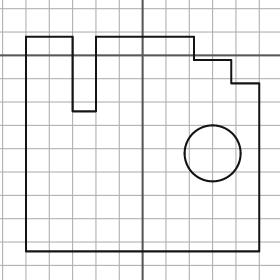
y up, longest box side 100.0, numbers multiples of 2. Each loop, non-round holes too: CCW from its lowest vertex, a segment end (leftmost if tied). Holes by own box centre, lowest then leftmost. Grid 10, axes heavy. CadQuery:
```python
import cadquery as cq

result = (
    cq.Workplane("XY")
    .moveTo(-50.0, -84.0)
    .lineTo(50.0, -84.0)
    .lineTo(50.0, -12.0)
    .lineTo(38.0, -12.0)
    .lineTo(38.0, -2.0)
    .lineTo(22.0, -2.0)
    .lineTo(22.0, 8.0)
    .lineTo(-20.0, 8.0)
    .lineTo(-20.0, -24.0)
    .lineTo(-30.0, -24.0)
    .lineTo(-30.0, 8.0)
    .lineTo(-50.0, 8.0)
    .close()
    .moveTo(30.0, -42.0)
    .circle(12.0)
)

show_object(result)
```